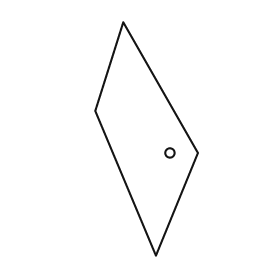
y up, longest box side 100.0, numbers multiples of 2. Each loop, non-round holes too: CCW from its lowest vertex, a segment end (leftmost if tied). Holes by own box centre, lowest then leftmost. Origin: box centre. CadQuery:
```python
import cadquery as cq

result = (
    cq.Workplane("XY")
    .moveTo(4.0, -50.0)
    .lineTo(22.0, -6.0)
    .lineTo(-10.0, 50.0)
    .lineTo(-22.0, 12.0)
    .close()
    .moveTo(10.0, -6.0)
    .circle(2.0)
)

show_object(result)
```